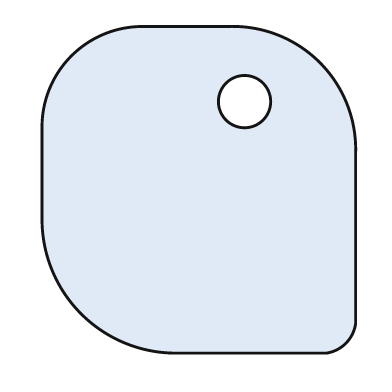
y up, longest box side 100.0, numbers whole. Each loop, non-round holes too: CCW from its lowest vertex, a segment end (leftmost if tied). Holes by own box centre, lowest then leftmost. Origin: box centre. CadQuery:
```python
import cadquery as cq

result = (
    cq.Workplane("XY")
    .moveTo(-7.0, -50.0)
    .lineTo(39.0, -50.0)
    .threePointArc((45.0, -47.0), (48.0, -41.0))
    .lineTo(48.0, 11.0)
    .threePointArc((37.0, 39.0), (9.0, 50.0))
    .lineTo(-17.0, 50.0)
    .threePointArc((-39.0, 41.0), (-48.0, 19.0))
    .lineTo(-48.0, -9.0)
    .threePointArc((-36.0, -38.0), (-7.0, -50.0))
    .close()
    .moveTo(14.0, 27.0)
    .circle(8.0)
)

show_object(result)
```